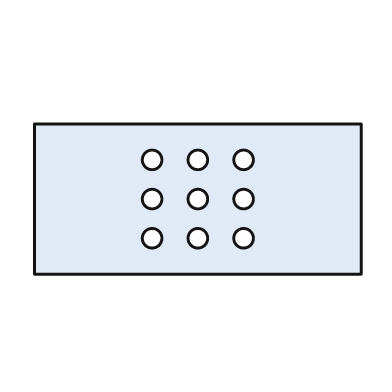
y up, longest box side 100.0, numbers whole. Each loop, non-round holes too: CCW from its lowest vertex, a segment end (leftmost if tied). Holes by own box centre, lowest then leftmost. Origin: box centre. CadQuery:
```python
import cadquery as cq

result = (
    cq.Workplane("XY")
    .moveTo(-50.0, -23.0)
    .lineTo(50.0, -23.0)
    .lineTo(50.0, 23.0)
    .lineTo(-50.0, 23.0)
    .close()
    .moveTo(-14.0, -12.0)
    .circle(3.0)
    .moveTo(0.0, -12.0)
    .circle(3.0)
    .moveTo(14.0, -12.0)
    .circle(3.0)
    .moveTo(-14.0, 0.0)
    .circle(3.0)
    .moveTo(0.0, 0.0)
    .circle(3.0)
    .moveTo(14.0, 0.0)
    .circle(3.0)
    .moveTo(-14.0, 12.0)
    .circle(3.0)
    .moveTo(0.0, 12.0)
    .circle(3.0)
    .moveTo(14.0, 12.0)
    .circle(3.0)
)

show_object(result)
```